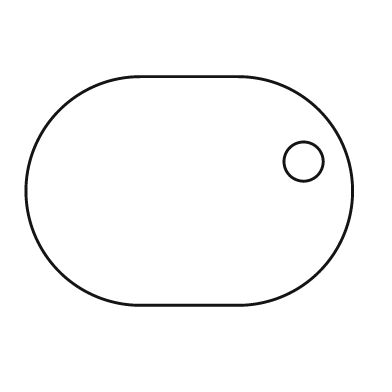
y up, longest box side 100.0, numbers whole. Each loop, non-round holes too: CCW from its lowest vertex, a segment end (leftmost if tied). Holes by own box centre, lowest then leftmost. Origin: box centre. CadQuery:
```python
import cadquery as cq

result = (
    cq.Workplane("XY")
    .moveTo(-15.0, -35.0)
    .lineTo(15.0, -35.0)
    .threePointArc((50.0, 0.0), (15.0, 35.0))
    .lineTo(-15.0, 35.0)
    .threePointArc((-50.0, 0.0), (-15.0, -35.0))
    .close()
    .moveTo(35.0, 9.0)
    .circle(6.0)
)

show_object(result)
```